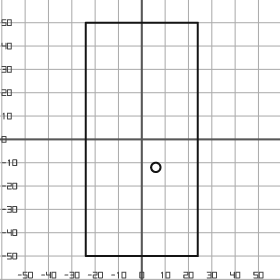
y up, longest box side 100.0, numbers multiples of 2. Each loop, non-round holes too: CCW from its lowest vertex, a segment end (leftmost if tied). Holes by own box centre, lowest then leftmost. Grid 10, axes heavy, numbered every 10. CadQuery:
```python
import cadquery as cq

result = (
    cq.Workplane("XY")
    .moveTo(-24.0, -50.0)
    .lineTo(24.0, -50.0)
    .lineTo(24.0, 50.0)
    .lineTo(-24.0, 50.0)
    .close()
    .moveTo(6.0, -12.0)
    .circle(2.0)
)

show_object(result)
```